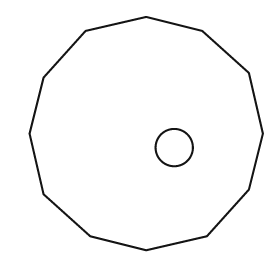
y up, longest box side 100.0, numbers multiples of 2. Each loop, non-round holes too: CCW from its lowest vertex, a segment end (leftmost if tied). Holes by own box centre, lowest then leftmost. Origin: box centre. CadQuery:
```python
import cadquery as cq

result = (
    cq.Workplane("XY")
    .moveTo(0.0, -50.0)
    .lineTo(26.0, -44.0)
    .lineTo(44.0, -24.0)
    .lineTo(50.0, 0.0)
    .lineTo(44.0, 26.0)
    .lineTo(24.0, 44.0)
    .lineTo(0.0, 50.0)
    .lineTo(-26.0, 44.0)
    .lineTo(-44.0, 24.0)
    .lineTo(-50.0, 0.0)
    .lineTo(-44.0, -26.0)
    .lineTo(-24.0, -44.0)
    .close()
    .moveTo(12.0, -6.0)
    .circle(8.0)
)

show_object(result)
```